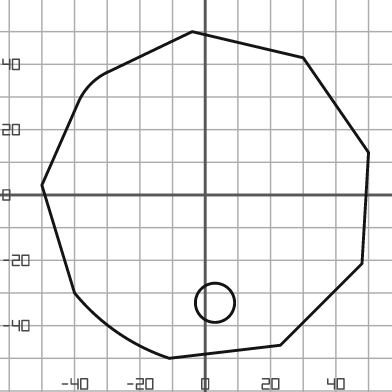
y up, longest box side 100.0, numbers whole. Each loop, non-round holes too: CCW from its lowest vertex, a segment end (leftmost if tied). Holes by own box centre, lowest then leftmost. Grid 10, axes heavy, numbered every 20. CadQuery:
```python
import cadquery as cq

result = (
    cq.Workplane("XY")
    .moveTo(-11.0, -50.0)
    .lineTo(23.0, -46.0)
    .lineTo(48.0, -21.0)
    .lineTo(50.0, 13.0)
    .lineTo(30.0, 42.0)
    .lineTo(-4.0, 50.0)
    .lineTo(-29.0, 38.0)
    .threePointArc((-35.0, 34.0), (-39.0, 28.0))
    .lineTo(-50.0, 3.0)
    .lineTo(-40.0, -30.0)
    .threePointArc((-27.0, -42.0), (-11.0, -50.0))
    .close()
    .moveTo(3.0, -33.0)
    .circle(6.0)
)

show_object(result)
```